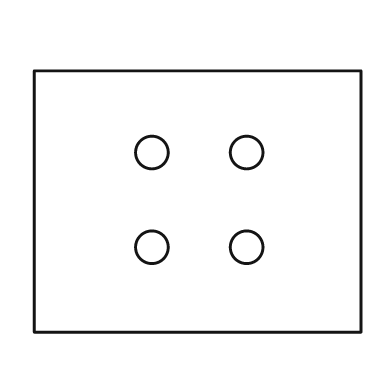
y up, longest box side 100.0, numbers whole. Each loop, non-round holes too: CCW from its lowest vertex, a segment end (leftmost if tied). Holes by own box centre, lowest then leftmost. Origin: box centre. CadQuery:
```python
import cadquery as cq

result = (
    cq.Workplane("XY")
    .moveTo(-50.0, -40.0)
    .lineTo(50.0, -40.0)
    .lineTo(50.0, 40.0)
    .lineTo(-50.0, 40.0)
    .close()
    .moveTo(-14.0, -14.0)
    .circle(5.0)
    .moveTo(15.0, -14.0)
    .circle(5.0)
    .moveTo(-14.0, 15.0)
    .circle(5.0)
    .moveTo(15.0, 15.0)
    .circle(5.0)
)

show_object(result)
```